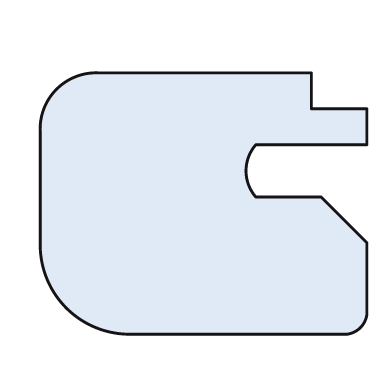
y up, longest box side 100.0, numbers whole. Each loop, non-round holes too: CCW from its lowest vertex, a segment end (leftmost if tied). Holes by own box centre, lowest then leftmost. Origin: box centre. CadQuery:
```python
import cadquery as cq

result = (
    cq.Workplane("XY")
    .moveTo(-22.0, -40.0)
    .lineTo(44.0, -40.0)
    .threePointArc((48.0, -38.0), (50.0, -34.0))
    .lineTo(50.0, -12.0)
    .lineTo(36.0, 2.0)
    .lineTo(16.0, 2.0)
    .threePointArc((13.0, 10.0), (16.0, 18.0))
    .lineTo(50.0, 18.0)
    .lineTo(50.0, 29.0)
    .lineTo(33.0, 29.0)
    .lineTo(33.0, 40.0)
    .lineTo(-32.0, 40.0)
    .threePointArc((-45.0, 35.0), (-50.0, 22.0))
    .lineTo(-50.0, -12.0)
    .threePointArc((-42.0, -32.0), (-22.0, -40.0))
    .close()
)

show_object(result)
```